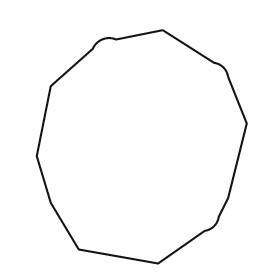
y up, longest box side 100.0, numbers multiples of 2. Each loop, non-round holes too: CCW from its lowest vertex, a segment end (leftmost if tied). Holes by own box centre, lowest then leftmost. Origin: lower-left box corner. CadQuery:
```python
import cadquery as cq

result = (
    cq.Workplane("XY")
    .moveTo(52.0, 0.0)
    .lineTo(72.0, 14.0)
    .threePointArc((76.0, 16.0), (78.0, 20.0))
    .lineTo(82.0, 28.0)
    .lineTo(90.0, 60.0)
    .lineTo(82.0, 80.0)
    .threePointArc((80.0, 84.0), (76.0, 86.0))
    .lineTo(54.0, 100.0)
    .lineTo(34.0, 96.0)
    .threePointArc((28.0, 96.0), (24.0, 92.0))
    .lineTo(6.0, 76.0)
    .lineTo(0.0, 46.0)
    .lineTo(6.0, 26.0)
    .lineTo(18.0, 6.0)
    .close()
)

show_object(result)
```